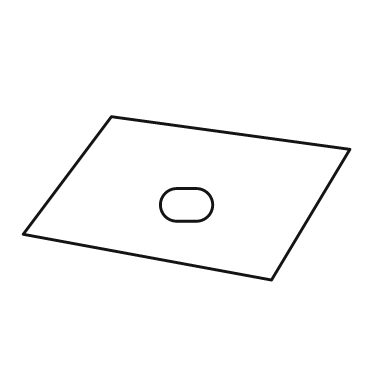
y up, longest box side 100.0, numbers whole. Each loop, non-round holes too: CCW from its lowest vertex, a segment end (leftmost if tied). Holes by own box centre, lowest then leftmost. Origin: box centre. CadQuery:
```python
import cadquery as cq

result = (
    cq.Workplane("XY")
    .moveTo(26.0, -25.0)
    .lineTo(50.0, 15.0)
    .lineTo(-23.0, 25.0)
    .lineTo(-50.0, -11.0)
    .close()
    .moveTo(-3.0, -7.0)
    .lineTo(3.0, -7.0)
    .threePointArc((8.0, -2.0), (3.0, 3.0))
    .lineTo(-3.0, 3.0)
    .threePointArc((-8.0, -2.0), (-3.0, -7.0))
    .close()
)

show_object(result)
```